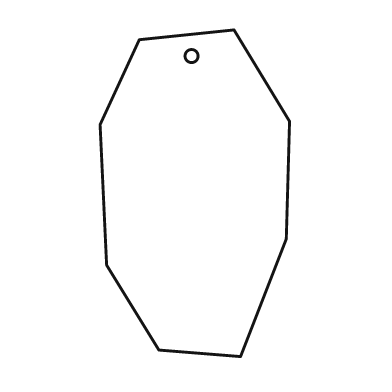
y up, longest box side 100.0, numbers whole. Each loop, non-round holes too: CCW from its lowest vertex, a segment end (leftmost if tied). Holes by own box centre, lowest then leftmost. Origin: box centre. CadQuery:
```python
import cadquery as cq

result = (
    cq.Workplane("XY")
    .moveTo(14.0, -50.0)
    .lineTo(28.0, -14.0)
    .lineTo(29.0, 22.0)
    .lineTo(12.0, 50.0)
    .lineTo(-17.0, 47.0)
    .lineTo(-29.0, 21.0)
    .lineTo(-27.0, -22.0)
    .lineTo(-11.0, -48.0)
    .close()
    .moveTo(-1.0, 42.0)
    .circle(2.0)
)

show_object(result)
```